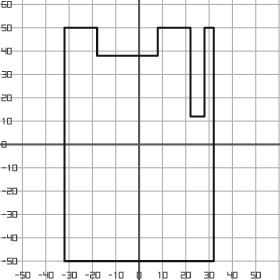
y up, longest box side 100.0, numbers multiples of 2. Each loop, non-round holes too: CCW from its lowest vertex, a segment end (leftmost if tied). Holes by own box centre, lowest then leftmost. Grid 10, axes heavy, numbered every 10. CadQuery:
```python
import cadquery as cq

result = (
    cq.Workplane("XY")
    .moveTo(-32.0, -50.0)
    .lineTo(32.0, -50.0)
    .lineTo(32.0, 50.0)
    .lineTo(28.0, 50.0)
    .lineTo(28.0, 12.0)
    .lineTo(22.0, 12.0)
    .lineTo(22.0, 50.0)
    .lineTo(8.0, 50.0)
    .lineTo(8.0, 38.0)
    .lineTo(-18.0, 38.0)
    .lineTo(-18.0, 50.0)
    .lineTo(-32.0, 50.0)
    .close()
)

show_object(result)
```